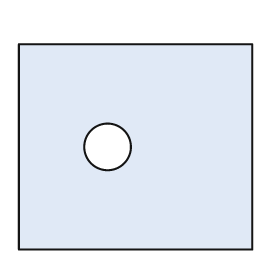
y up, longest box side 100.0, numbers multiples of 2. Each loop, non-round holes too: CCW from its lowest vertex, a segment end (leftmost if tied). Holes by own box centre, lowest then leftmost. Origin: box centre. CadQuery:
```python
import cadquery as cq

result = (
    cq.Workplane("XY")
    .moveTo(-50.0, -44.0)
    .lineTo(50.0, -44.0)
    .lineTo(50.0, 44.0)
    .lineTo(-50.0, 44.0)
    .close()
    .moveTo(-12.0, 0.0)
    .circle(10.0)
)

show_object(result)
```